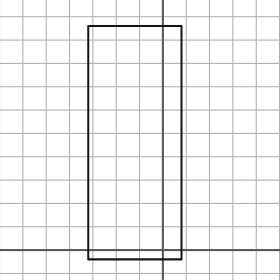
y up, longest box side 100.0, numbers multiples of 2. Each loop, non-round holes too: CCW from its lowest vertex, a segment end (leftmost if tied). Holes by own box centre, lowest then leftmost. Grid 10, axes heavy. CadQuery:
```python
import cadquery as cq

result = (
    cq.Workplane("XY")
    .moveTo(-32.0, -4.0)
    .lineTo(8.0, -4.0)
    .lineTo(8.0, 96.0)
    .lineTo(-32.0, 96.0)
    .close()
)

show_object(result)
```